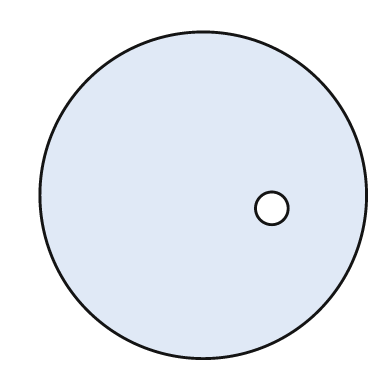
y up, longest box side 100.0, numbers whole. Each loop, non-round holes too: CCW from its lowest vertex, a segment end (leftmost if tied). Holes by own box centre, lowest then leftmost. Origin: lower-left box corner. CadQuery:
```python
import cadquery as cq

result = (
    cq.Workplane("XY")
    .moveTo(50.0, 50.0)
    .circle(50.0)
    .moveTo(71.0, 46.0)
    .circle(5.0)
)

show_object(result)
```